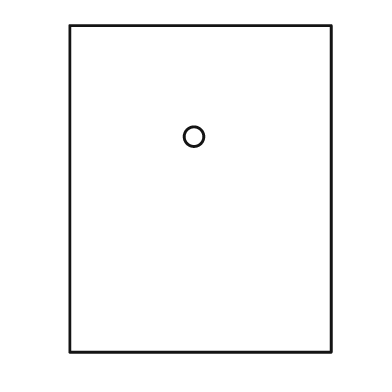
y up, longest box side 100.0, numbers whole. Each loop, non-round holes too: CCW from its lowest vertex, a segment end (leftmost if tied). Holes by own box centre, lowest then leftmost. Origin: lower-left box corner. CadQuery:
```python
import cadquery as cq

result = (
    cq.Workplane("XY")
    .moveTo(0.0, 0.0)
    .lineTo(80.0, 0.0)
    .lineTo(80.0, 100.0)
    .lineTo(0.0, 100.0)
    .close()
    .moveTo(38.0, 66.0)
    .circle(3.0)
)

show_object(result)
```